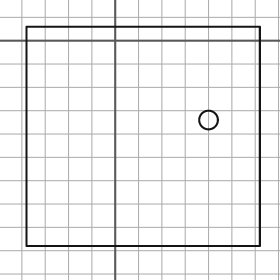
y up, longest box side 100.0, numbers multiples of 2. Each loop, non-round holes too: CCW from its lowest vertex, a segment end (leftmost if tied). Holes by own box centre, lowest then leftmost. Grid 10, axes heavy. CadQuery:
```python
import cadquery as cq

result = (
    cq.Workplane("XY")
    .moveTo(-38.0, -88.0)
    .lineTo(62.0, -88.0)
    .lineTo(62.0, 6.0)
    .lineTo(-38.0, 6.0)
    .close()
    .moveTo(40.0, -34.0)
    .circle(4.0)
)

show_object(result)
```